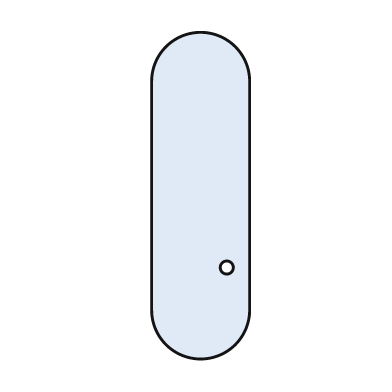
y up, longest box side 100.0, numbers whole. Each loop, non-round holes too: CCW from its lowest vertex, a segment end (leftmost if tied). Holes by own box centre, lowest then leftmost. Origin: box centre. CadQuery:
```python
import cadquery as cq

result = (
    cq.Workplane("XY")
    .moveTo(-15.0, -35.0)
    .threePointArc((0.0, -50.0), (15.0, -35.0))
    .lineTo(15.0, 35.0)
    .threePointArc((0.0, 50.0), (-15.0, 35.0))
    .close()
    .moveTo(8.0, -22.0)
    .circle(2.0)
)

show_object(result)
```